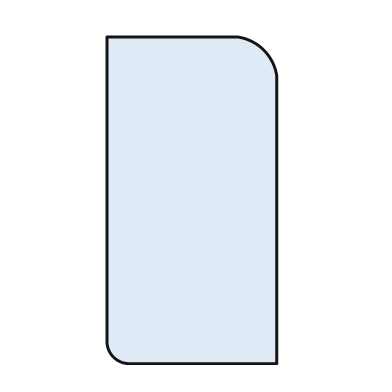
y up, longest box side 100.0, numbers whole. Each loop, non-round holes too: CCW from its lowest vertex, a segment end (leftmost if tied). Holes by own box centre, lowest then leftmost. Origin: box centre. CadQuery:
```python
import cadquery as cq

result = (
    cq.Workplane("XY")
    .moveTo(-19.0, -50.0)
    .lineTo(26.0, -50.0)
    .lineTo(26.0, 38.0)
    .threePointArc((22.0, 46.0), (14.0, 50.0))
    .lineTo(-26.0, 50.0)
    .lineTo(-26.0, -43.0)
    .threePointArc((-24.0, -48.0), (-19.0, -50.0))
    .close()
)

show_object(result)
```